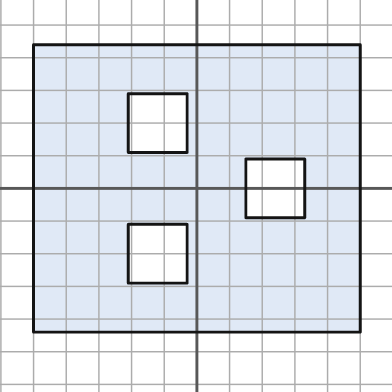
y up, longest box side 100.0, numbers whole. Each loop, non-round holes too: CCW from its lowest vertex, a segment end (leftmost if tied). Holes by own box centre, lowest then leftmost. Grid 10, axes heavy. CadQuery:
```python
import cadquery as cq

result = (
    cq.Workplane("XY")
    .moveTo(-50.0, -44.0)
    .lineTo(50.0, -44.0)
    .lineTo(50.0, 44.0)
    .lineTo(-50.0, 44.0)
    .close()
    .moveTo(-21.0, -29.0)
    .lineTo(-3.0, -29.0)
    .lineTo(-3.0, -11.0)
    .lineTo(-21.0, -11.0)
    .close()
    .moveTo(15.0, -9.0)
    .lineTo(33.0, -9.0)
    .lineTo(33.0, 9.0)
    .lineTo(15.0, 9.0)
    .close()
    .moveTo(-21.0, 11.0)
    .lineTo(-3.0, 11.0)
    .lineTo(-3.0, 29.0)
    .lineTo(-21.0, 29.0)
    .close()
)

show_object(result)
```